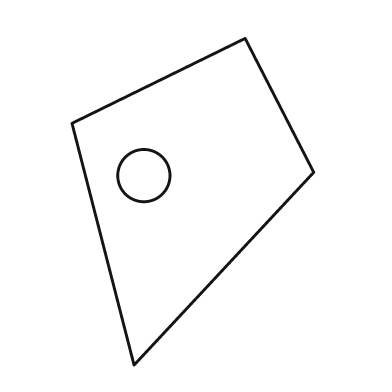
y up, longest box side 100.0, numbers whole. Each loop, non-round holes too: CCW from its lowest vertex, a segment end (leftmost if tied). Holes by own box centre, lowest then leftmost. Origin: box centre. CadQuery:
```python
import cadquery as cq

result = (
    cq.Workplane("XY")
    .moveTo(-18.0, -50.0)
    .lineTo(37.0, 9.0)
    .lineTo(16.0, 50.0)
    .lineTo(-37.0, 24.0)
    .close()
    .moveTo(-15.0, 8.0)
    .circle(8.0)
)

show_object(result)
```